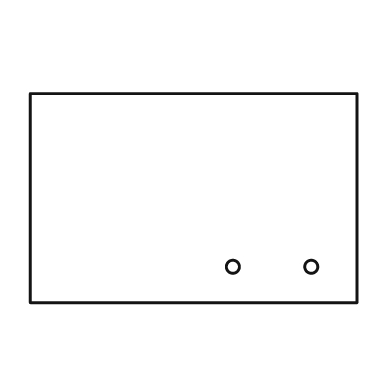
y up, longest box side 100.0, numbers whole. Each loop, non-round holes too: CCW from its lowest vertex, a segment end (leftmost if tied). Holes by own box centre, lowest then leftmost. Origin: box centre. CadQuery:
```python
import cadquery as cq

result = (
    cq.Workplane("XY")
    .moveTo(-50.0, -32.0)
    .lineTo(50.0, -32.0)
    .lineTo(50.0, 32.0)
    .lineTo(-50.0, 32.0)
    .close()
    .moveTo(12.0, -21.0)
    .circle(2.0)
    .moveTo(36.0, -21.0)
    .circle(2.0)
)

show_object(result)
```